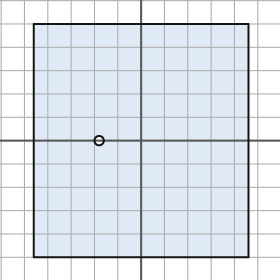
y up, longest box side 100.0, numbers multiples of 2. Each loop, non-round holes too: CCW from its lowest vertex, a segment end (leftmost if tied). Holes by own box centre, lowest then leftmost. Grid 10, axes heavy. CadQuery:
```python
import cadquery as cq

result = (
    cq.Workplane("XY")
    .moveTo(-46.0, -50.0)
    .lineTo(46.0, -50.0)
    .lineTo(46.0, 50.0)
    .lineTo(-46.0, 50.0)
    .close()
    .moveTo(-18.0, 0.0)
    .circle(2.0)
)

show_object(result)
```